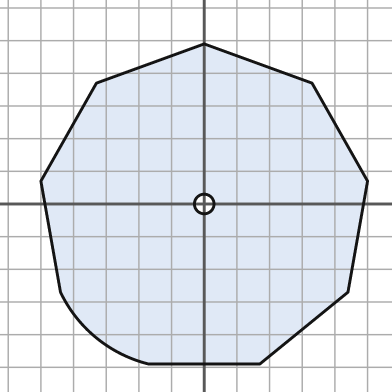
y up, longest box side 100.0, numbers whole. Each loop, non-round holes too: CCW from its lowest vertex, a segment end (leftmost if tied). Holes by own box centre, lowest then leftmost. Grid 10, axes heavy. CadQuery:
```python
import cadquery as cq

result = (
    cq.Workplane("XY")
    .moveTo(-17.0, -49.0)
    .lineTo(17.0, -49.0)
    .lineTo(44.0, -27.0)
    .lineTo(50.0, 7.0)
    .lineTo(33.0, 37.0)
    .lineTo(0.0, 49.0)
    .lineTo(-33.0, 37.0)
    .lineTo(-50.0, 7.0)
    .lineTo(-44.0, -27.0)
    .threePointArc((-33.0, -41.0), (-17.0, -49.0))
    .close()
    .moveTo(0.0, 0.0)
    .circle(3.0)
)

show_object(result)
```